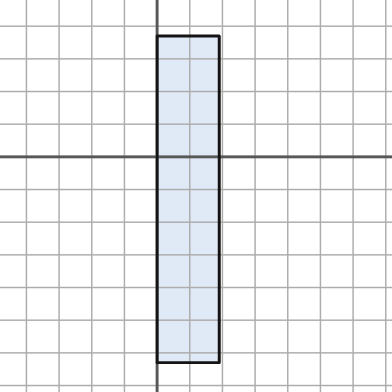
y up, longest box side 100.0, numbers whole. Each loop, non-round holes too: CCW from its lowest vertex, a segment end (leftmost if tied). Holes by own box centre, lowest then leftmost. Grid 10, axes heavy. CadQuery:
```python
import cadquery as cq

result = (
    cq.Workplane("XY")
    .moveTo(0.0, -63.0)
    .lineTo(19.0, -63.0)
    .lineTo(19.0, 37.0)
    .lineTo(0.0, 37.0)
    .close()
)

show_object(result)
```